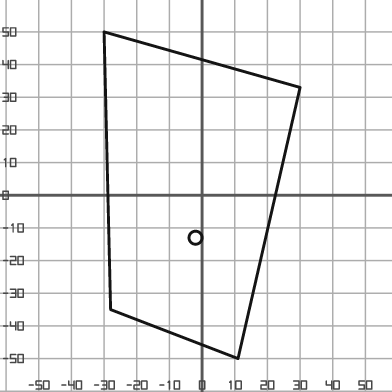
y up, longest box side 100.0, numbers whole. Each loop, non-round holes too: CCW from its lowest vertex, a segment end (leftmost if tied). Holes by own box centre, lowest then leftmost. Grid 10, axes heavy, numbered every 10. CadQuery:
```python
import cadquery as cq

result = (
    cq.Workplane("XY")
    .moveTo(11.0, -50.0)
    .lineTo(30.0, 33.0)
    .lineTo(-30.0, 50.0)
    .lineTo(-28.0, -35.0)
    .close()
    .moveTo(-2.0, -13.0)
    .circle(2.0)
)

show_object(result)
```